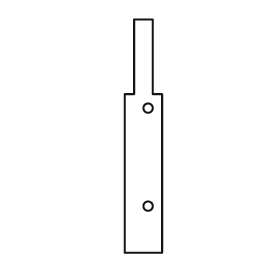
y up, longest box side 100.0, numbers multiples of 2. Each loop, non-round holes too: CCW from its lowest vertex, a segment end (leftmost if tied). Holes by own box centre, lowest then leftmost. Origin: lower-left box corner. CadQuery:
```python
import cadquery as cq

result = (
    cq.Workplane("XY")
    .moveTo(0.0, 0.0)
    .lineTo(16.0, 0.0)
    .lineTo(16.0, 68.0)
    .lineTo(12.0, 68.0)
    .lineTo(12.0, 100.0)
    .lineTo(4.0, 100.0)
    .lineTo(4.0, 68.0)
    .lineTo(0.0, 68.0)
    .close()
    .moveTo(10.0, 20.0)
    .circle(2.0)
    .moveTo(10.0, 62.0)
    .circle(2.0)
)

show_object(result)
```